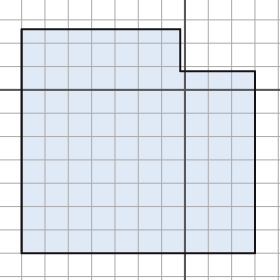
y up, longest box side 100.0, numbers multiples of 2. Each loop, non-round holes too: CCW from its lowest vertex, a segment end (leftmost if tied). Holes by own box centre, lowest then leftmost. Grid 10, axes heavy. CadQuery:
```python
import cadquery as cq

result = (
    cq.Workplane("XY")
    .moveTo(-70.0, -70.0)
    .lineTo(30.0, -70.0)
    .lineTo(30.0, 8.0)
    .lineTo(-2.0, 8.0)
    .lineTo(-2.0, 26.0)
    .lineTo(-70.0, 26.0)
    .close()
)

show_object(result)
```